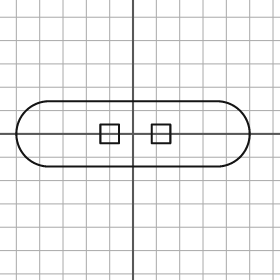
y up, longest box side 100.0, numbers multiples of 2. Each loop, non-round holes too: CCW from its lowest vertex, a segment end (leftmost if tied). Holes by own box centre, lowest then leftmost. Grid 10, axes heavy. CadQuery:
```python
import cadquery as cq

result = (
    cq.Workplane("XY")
    .moveTo(-36.0, -14.0)
    .lineTo(36.0, -14.0)
    .threePointArc((50.0, 0.0), (36.0, 14.0))
    .lineTo(-36.0, 14.0)
    .threePointArc((-50.0, 0.0), (-36.0, -14.0))
    .close()
    .moveTo(-14.0, -4.0)
    .lineTo(-6.0, -4.0)
    .lineTo(-6.0, 4.0)
    .lineTo(-14.0, 4.0)
    .close()
    .moveTo(8.0, -4.0)
    .lineTo(16.0, -4.0)
    .lineTo(16.0, 4.0)
    .lineTo(8.0, 4.0)
    .close()
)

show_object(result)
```